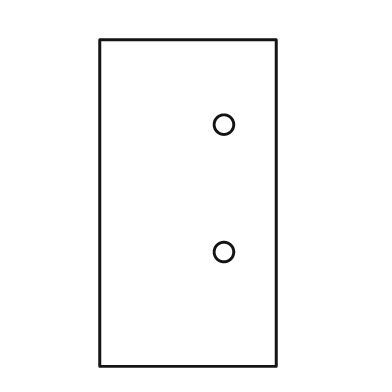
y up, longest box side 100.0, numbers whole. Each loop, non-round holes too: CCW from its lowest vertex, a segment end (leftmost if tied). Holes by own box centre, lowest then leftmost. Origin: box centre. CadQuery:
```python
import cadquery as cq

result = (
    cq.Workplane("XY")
    .moveTo(-27.0, -50.0)
    .lineTo(27.0, -50.0)
    .lineTo(27.0, 50.0)
    .lineTo(-27.0, 50.0)
    .close()
    .moveTo(11.0, -15.0)
    .circle(3.0)
    .moveTo(11.0, 24.0)
    .circle(3.0)
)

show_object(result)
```